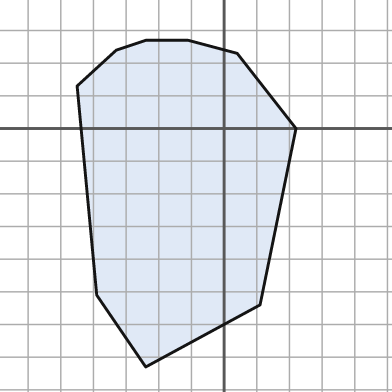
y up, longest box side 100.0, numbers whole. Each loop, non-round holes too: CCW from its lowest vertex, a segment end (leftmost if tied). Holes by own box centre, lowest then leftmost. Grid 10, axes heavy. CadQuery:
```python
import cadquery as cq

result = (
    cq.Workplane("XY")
    .moveTo(-24.0, -73.0)
    .lineTo(11.0, -54.0)
    .lineTo(22.0, 0.0)
    .lineTo(4.0, 23.0)
    .lineTo(-11.0, 27.0)
    .lineTo(-24.0, 27.0)
    .lineTo(-33.0, 24.0)
    .lineTo(-45.0, 13.0)
    .lineTo(-39.0, -51.0)
    .close()
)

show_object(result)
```